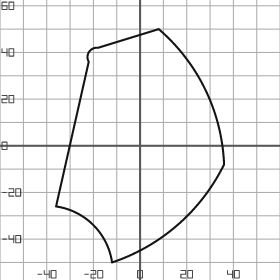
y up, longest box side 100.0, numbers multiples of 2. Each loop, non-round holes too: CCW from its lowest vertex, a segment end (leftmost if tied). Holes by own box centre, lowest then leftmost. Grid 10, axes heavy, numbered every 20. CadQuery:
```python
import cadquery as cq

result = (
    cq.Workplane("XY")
    .moveTo(-12.0, -50.0)
    .threePointArc((16.0, -34.0), (36.0, -8.0))
    .threePointArc((28.0, 24.0), (8.0, 50.0))
    .lineTo(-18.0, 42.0)
    .threePointArc((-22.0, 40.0), (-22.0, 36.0))
    .lineTo(-36.0, -26.0)
    .threePointArc((-20.0, -34.0), (-12.0, -50.0))
    .close()
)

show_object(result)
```